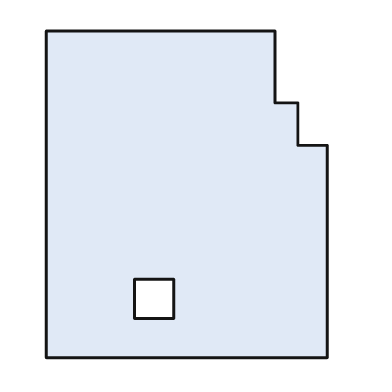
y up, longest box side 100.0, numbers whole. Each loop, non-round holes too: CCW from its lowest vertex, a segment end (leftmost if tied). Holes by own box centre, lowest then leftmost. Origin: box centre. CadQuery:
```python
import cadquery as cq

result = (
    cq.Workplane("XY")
    .moveTo(-43.0, -50.0)
    .lineTo(43.0, -50.0)
    .lineTo(43.0, 15.0)
    .lineTo(34.0, 15.0)
    .lineTo(34.0, 28.0)
    .lineTo(27.0, 28.0)
    .lineTo(27.0, 50.0)
    .lineTo(-43.0, 50.0)
    .close()
    .moveTo(-16.0, -38.0)
    .lineTo(-4.0, -38.0)
    .lineTo(-4.0, -26.0)
    .lineTo(-16.0, -26.0)
    .close()
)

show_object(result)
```